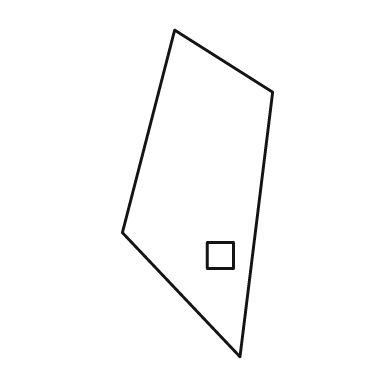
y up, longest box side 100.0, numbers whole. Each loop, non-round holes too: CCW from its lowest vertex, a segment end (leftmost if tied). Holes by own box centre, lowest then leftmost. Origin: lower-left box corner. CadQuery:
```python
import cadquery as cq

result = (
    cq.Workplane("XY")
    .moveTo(36.0, 0.0)
    .lineTo(46.0, 81.0)
    .lineTo(16.0, 100.0)
    .lineTo(0.0, 38.0)
    .close()
    .moveTo(26.0, 27.0)
    .lineTo(34.0, 27.0)
    .lineTo(34.0, 35.0)
    .lineTo(26.0, 35.0)
    .close()
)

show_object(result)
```